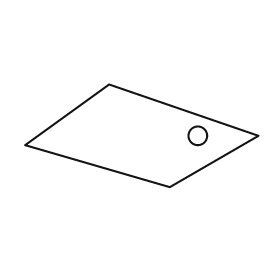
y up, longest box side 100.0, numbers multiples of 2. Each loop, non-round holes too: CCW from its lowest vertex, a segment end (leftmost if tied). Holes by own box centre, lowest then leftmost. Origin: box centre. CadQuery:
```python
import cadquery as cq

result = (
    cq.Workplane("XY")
    .moveTo(12.0, -22.0)
    .lineTo(50.0, 0.0)
    .lineTo(-14.0, 22.0)
    .lineTo(-50.0, -4.0)
    .close()
    .moveTo(24.0, 0.0)
    .circle(4.0)
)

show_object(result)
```